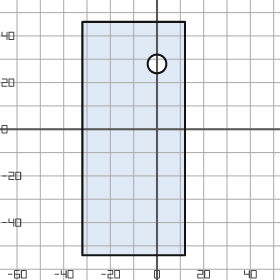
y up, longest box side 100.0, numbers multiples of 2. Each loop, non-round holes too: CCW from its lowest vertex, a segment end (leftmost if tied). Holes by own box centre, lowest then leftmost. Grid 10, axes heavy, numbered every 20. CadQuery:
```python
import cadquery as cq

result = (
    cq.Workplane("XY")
    .moveTo(-32.0, -54.0)
    .lineTo(12.0, -54.0)
    .lineTo(12.0, 46.0)
    .lineTo(-32.0, 46.0)
    .close()
    .moveTo(0.0, 28.0)
    .circle(4.0)
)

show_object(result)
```